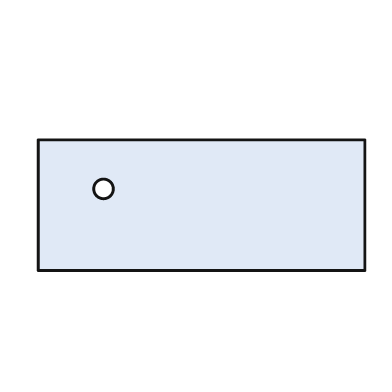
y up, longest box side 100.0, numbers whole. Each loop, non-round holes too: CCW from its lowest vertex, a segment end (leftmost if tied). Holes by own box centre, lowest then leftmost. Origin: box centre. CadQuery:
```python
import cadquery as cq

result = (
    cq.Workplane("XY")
    .moveTo(-50.0, -20.0)
    .lineTo(50.0, -20.0)
    .lineTo(50.0, 20.0)
    .lineTo(-50.0, 20.0)
    .close()
    .moveTo(-30.0, 5.0)
    .circle(3.0)
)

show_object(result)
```